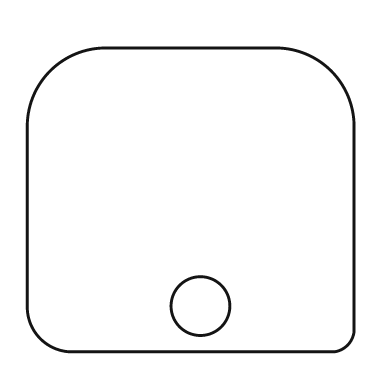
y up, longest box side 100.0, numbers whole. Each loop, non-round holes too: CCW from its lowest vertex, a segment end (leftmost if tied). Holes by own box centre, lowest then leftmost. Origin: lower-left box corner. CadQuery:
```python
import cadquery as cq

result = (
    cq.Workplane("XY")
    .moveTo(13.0, 0.0)
    .lineTo(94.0, 0.0)
    .threePointArc((98.0, 2.0), (100.0, 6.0))
    .lineTo(100.0, 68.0)
    .threePointArc((93.0, 86.0), (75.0, 93.0))
    .lineTo(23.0, 93.0)
    .threePointArc((7.0, 86.0), (0.0, 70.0))
    .lineTo(0.0, 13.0)
    .threePointArc((4.0, 4.0), (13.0, 0.0))
    .close()
    .moveTo(53.0, 14.0)
    .circle(9.0)
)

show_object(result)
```